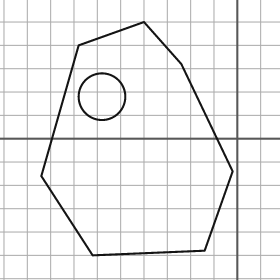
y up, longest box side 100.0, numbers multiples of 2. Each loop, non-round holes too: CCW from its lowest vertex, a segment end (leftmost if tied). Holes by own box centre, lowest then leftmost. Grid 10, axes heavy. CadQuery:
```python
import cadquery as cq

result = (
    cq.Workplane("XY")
    .moveTo(-62.0, -50.0)
    .lineTo(-14.0, -48.0)
    .lineTo(-2.0, -14.0)
    .lineTo(-24.0, 32.0)
    .lineTo(-40.0, 50.0)
    .lineTo(-68.0, 40.0)
    .lineTo(-84.0, -16.0)
    .close()
    .moveTo(-58.0, 18.0)
    .circle(10.0)
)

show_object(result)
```